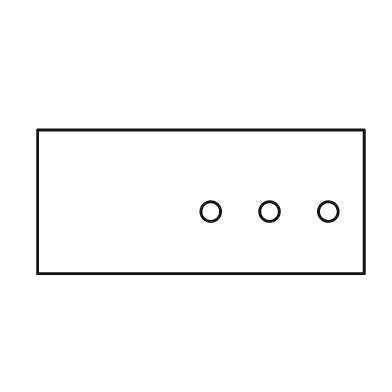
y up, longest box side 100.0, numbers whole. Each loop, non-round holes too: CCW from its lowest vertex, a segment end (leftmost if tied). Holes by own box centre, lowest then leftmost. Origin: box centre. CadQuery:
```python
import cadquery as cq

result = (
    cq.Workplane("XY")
    .moveTo(-50.0, -22.0)
    .lineTo(50.0, -22.0)
    .lineTo(50.0, 22.0)
    .lineTo(-50.0, 22.0)
    .close()
    .moveTo(3.0, -3.0)
    .circle(3.0)
    .moveTo(21.0, -3.0)
    .circle(3.0)
    .moveTo(39.0, -3.0)
    .circle(3.0)
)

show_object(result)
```